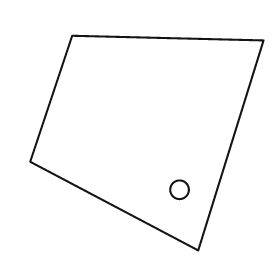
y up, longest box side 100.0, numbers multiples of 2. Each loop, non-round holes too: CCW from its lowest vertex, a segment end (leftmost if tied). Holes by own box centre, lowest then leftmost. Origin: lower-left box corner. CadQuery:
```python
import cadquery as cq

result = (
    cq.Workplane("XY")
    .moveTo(72.0, 0.0)
    .lineTo(100.0, 90.0)
    .lineTo(18.0, 92.0)
    .lineTo(0.0, 38.0)
    .close()
    .moveTo(64.0, 26.0)
    .circle(4.0)
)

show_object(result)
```